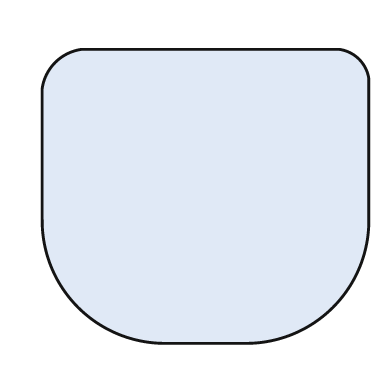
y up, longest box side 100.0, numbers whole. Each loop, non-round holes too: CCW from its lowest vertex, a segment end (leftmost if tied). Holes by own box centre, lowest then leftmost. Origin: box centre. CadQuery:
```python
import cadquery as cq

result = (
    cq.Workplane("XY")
    .moveTo(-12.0, -45.0)
    .lineTo(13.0, -45.0)
    .threePointArc((39.0, -34.0), (50.0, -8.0))
    .lineTo(50.0, 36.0)
    .threePointArc((47.0, 42.0), (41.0, 45.0))
    .lineTo(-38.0, 45.0)
    .threePointArc((-46.0, 41.0), (-50.0, 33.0))
    .lineTo(-50.0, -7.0)
    .threePointArc((-39.0, -34.0), (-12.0, -45.0))
    .close()
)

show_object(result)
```